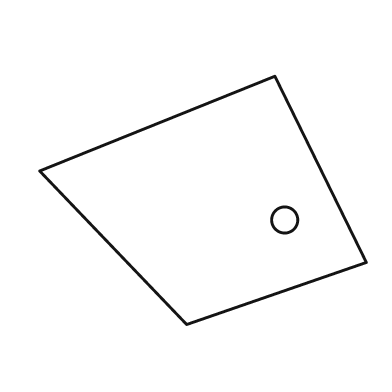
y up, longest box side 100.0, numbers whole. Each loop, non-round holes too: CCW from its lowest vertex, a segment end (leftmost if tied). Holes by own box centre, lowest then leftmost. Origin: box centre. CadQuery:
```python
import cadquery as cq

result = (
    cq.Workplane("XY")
    .moveTo(-5.0, -38.0)
    .lineTo(50.0, -19.0)
    .lineTo(22.0, 38.0)
    .lineTo(-50.0, 9.0)
    .close()
    .moveTo(25.0, -6.0)
    .circle(4.0)
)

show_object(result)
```